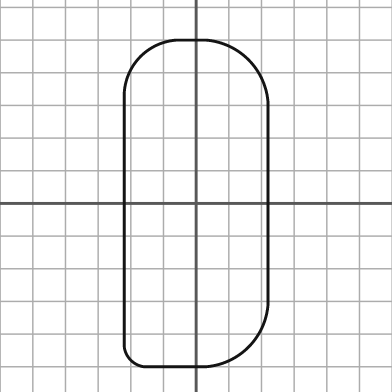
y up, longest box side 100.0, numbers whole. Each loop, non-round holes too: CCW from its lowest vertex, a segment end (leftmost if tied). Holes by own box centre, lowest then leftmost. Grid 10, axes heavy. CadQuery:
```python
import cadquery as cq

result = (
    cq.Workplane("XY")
    .moveTo(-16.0, -50.0)
    .lineTo(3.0, -50.0)
    .threePointArc((16.0, -44.0), (22.0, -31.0))
    .lineTo(22.0, 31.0)
    .threePointArc((16.0, 44.0), (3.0, 50.0))
    .lineTo(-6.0, 50.0)
    .threePointArc((-17.0, 45.0), (-22.0, 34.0))
    .lineTo(-22.0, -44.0)
    .threePointArc((-20.0, -48.0), (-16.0, -50.0))
    .close()
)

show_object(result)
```